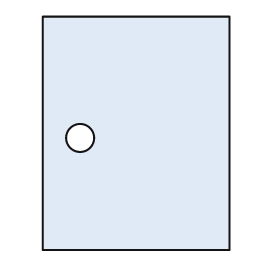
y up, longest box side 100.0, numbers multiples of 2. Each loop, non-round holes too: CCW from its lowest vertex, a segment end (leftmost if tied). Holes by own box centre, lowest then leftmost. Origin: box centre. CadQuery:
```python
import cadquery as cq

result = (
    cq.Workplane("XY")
    .moveTo(-40.0, -50.0)
    .lineTo(40.0, -50.0)
    .lineTo(40.0, 50.0)
    .lineTo(-40.0, 50.0)
    .close()
    .moveTo(-24.0, -2.0)
    .circle(6.0)
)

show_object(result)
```